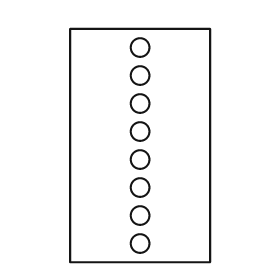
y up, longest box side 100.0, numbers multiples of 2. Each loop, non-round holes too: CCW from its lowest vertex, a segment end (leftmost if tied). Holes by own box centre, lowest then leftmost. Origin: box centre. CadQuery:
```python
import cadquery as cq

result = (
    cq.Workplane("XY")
    .moveTo(-30.0, -50.0)
    .lineTo(30.0, -50.0)
    .lineTo(30.0, 50.0)
    .lineTo(-30.0, 50.0)
    .close()
    .moveTo(0.0, -42.0)
    .circle(4.0)
    .moveTo(0.0, -30.0)
    .circle(4.0)
    .moveTo(0.0, -18.0)
    .circle(4.0)
    .moveTo(0.0, -6.0)
    .circle(4.0)
    .moveTo(0.0, 6.0)
    .circle(4.0)
    .moveTo(0.0, 18.0)
    .circle(4.0)
    .moveTo(0.0, 30.0)
    .circle(4.0)
    .moveTo(0.0, 42.0)
    .circle(4.0)
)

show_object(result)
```